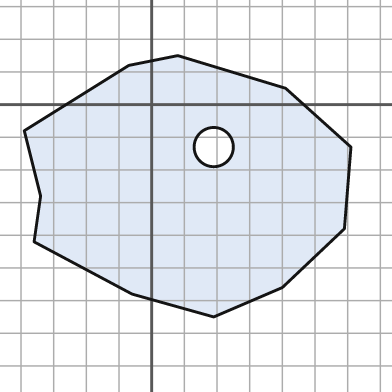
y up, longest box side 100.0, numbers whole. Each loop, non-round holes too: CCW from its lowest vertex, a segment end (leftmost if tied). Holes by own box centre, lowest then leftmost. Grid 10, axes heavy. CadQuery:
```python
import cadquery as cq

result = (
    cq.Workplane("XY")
    .moveTo(19.0, -65.0)
    .lineTo(40.0, -56.0)
    .lineTo(59.0, -38.0)
    .lineTo(61.0, -13.0)
    .lineTo(41.0, 5.0)
    .lineTo(8.0, 15.0)
    .lineTo(-7.0, 12.0)
    .lineTo(-39.0, -8.0)
    .lineTo(-34.0, -28.0)
    .lineTo(-36.0, -42.0)
    .lineTo(-6.0, -58.0)
    .close()
    .moveTo(19.0, -13.0)
    .circle(6.0)
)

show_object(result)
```